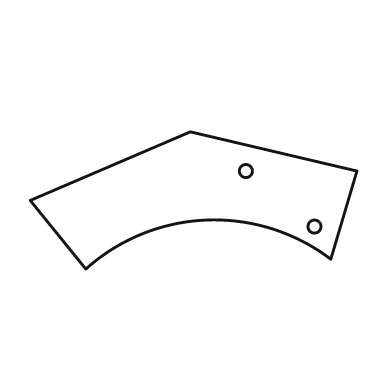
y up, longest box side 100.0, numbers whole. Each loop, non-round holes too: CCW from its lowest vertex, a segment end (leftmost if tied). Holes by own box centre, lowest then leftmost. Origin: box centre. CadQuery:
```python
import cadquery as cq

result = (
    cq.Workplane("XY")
    .moveTo(-33.0, -21.0)
    .threePointArc((4.0, -6.0), (42.0, -18.0))
    .lineTo(50.0, 9.0)
    .lineTo(-1.0, 21.0)
    .lineTo(-50.0, 0.0)
    .close()
    .moveTo(37.0, -8.0)
    .circle(2.0)
    .moveTo(16.0, 9.0)
    .circle(2.0)
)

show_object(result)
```